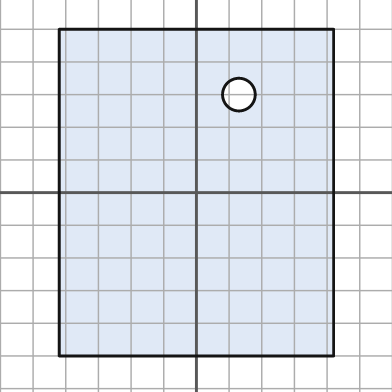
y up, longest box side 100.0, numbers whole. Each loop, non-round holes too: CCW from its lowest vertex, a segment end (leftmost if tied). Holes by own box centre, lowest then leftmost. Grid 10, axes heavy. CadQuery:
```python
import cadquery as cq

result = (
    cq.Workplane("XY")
    .moveTo(-42.0, -50.0)
    .lineTo(42.0, -50.0)
    .lineTo(42.0, 50.0)
    .lineTo(-42.0, 50.0)
    .close()
    .moveTo(13.0, 30.0)
    .circle(5.0)
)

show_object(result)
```